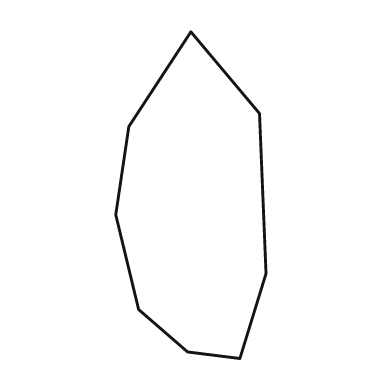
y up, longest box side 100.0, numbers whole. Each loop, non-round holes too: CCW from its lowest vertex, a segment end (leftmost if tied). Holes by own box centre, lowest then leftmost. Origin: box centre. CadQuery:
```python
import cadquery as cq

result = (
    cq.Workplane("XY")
    .moveTo(15.0, -50.0)
    .lineTo(23.0, -24.0)
    .lineTo(21.0, 25.0)
    .lineTo(0.0, 50.0)
    .lineTo(-19.0, 21.0)
    .lineTo(-23.0, -6.0)
    .lineTo(-16.0, -35.0)
    .lineTo(-1.0, -48.0)
    .close()
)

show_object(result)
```